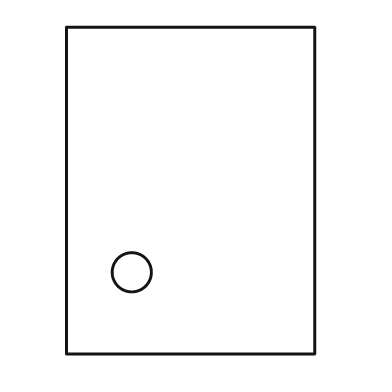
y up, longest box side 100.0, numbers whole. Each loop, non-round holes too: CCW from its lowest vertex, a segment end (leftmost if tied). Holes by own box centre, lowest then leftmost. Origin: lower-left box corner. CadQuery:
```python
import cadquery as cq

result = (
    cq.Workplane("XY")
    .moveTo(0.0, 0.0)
    .lineTo(76.0, 0.0)
    .lineTo(76.0, 100.0)
    .lineTo(0.0, 100.0)
    .close()
    .moveTo(20.0, 25.0)
    .circle(6.0)
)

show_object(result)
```